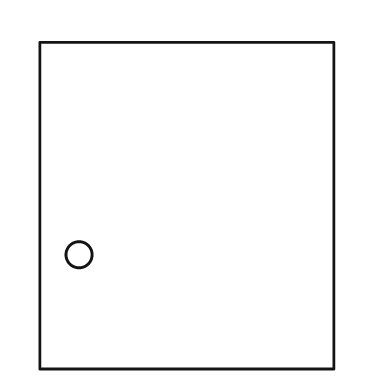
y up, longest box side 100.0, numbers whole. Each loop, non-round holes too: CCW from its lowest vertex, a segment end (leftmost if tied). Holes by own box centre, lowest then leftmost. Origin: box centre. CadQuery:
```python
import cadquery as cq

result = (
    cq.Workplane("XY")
    .moveTo(-45.0, -50.0)
    .lineTo(45.0, -50.0)
    .lineTo(45.0, 50.0)
    .lineTo(-45.0, 50.0)
    .close()
    .moveTo(-33.0, -15.0)
    .circle(4.0)
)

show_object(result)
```